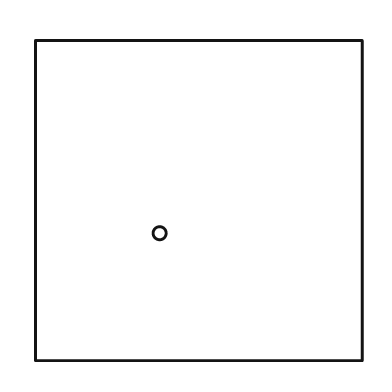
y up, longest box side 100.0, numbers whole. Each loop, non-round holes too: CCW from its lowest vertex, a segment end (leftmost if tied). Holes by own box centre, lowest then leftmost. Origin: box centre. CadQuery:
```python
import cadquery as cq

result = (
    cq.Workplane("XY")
    .moveTo(-50.0, -49.0)
    .lineTo(50.0, -49.0)
    .lineTo(50.0, 49.0)
    .lineTo(-50.0, 49.0)
    .close()
    .moveTo(-12.0, -10.0)
    .circle(2.0)
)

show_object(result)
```